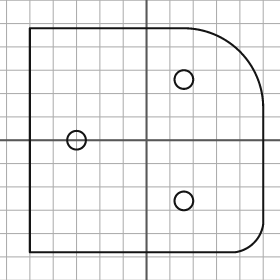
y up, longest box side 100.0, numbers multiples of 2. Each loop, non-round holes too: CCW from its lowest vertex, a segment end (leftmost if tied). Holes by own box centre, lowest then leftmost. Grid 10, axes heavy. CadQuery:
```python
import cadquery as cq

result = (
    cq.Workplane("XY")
    .moveTo(-50.0, -48.0)
    .lineTo(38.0, -48.0)
    .threePointArc((46.0, -44.0), (50.0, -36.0))
    .lineTo(50.0, 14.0)
    .threePointArc((40.0, 38.0), (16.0, 48.0))
    .lineTo(-50.0, 48.0)
    .close()
    .moveTo(16.0, -26.0)
    .circle(4.0)
    .moveTo(-30.0, 0.0)
    .circle(4.0)
    .moveTo(16.0, 26.0)
    .circle(4.0)
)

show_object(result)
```